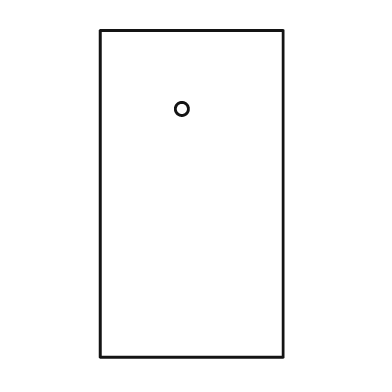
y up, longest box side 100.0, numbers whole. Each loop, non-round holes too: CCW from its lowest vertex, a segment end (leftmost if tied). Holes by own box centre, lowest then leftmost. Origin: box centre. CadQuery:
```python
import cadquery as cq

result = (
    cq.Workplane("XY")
    .moveTo(-28.0, -50.0)
    .lineTo(28.0, -50.0)
    .lineTo(28.0, 50.0)
    .lineTo(-28.0, 50.0)
    .close()
    .moveTo(-3.0, 26.0)
    .circle(2.0)
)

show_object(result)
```